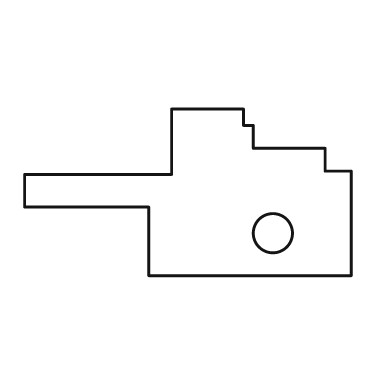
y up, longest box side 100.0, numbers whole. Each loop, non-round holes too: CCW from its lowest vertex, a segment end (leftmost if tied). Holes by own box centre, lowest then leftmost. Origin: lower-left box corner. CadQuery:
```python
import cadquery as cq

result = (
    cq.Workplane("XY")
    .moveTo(38.0, 0.0)
    .lineTo(100.0, 0.0)
    .lineTo(100.0, 32.0)
    .lineTo(92.0, 32.0)
    .lineTo(92.0, 39.0)
    .lineTo(70.0, 39.0)
    .lineTo(70.0, 46.0)
    .lineTo(67.0, 46.0)
    .lineTo(67.0, 51.0)
    .lineTo(45.0, 51.0)
    .lineTo(45.0, 31.0)
    .lineTo(0.0, 31.0)
    .lineTo(0.0, 21.0)
    .lineTo(38.0, 21.0)
    .close()
    .moveTo(76.0, 13.0)
    .circle(6.0)
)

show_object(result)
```